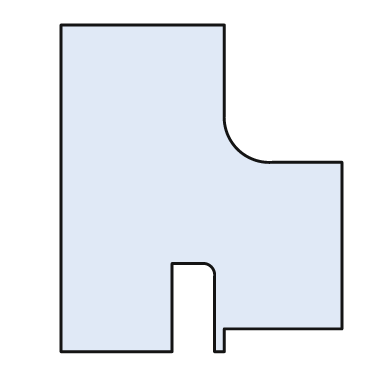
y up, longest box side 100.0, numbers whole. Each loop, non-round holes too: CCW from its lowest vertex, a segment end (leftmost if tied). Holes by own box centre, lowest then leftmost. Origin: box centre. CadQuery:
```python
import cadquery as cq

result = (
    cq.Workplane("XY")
    .moveTo(-43.0, -50.0)
    .lineTo(-9.0, -50.0)
    .lineTo(-9.0, -23.0)
    .lineTo(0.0, -23.0)
    .threePointArc((3.0, -24.0), (4.0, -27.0))
    .lineTo(4.0, -50.0)
    .lineTo(7.0, -50.0)
    .lineTo(7.0, -43.0)
    .lineTo(43.0, -43.0)
    .lineTo(43.0, 8.0)
    .lineTo(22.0, 8.0)
    .threePointArc((11.0, 12.0), (7.0, 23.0))
    .lineTo(7.0, 50.0)
    .lineTo(-43.0, 50.0)
    .close()
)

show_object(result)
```